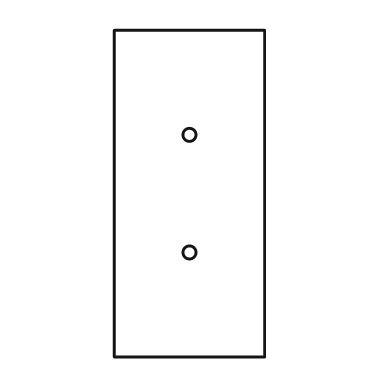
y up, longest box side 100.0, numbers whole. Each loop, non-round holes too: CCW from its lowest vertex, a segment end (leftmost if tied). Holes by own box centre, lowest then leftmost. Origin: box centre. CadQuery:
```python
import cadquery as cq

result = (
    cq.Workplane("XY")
    .moveTo(-23.0, -50.0)
    .lineTo(23.0, -50.0)
    .lineTo(23.0, 50.0)
    .lineTo(-23.0, 50.0)
    .close()
    .moveTo(0.0, -18.0)
    .circle(2.0)
    .moveTo(0.0, 18.0)
    .circle(2.0)
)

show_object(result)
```